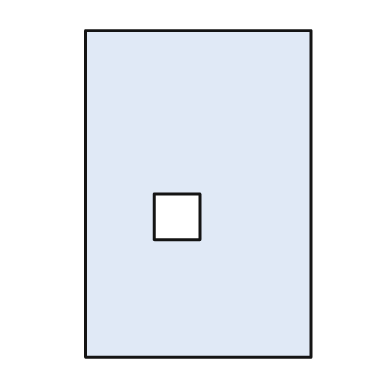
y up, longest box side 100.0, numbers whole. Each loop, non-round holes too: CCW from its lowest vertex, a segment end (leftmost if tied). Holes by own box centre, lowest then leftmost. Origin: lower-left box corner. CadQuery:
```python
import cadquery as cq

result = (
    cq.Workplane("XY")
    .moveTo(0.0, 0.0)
    .lineTo(69.0, 0.0)
    .lineTo(69.0, 100.0)
    .lineTo(0.0, 100.0)
    .close()
    .moveTo(21.0, 36.0)
    .lineTo(35.0, 36.0)
    .lineTo(35.0, 50.0)
    .lineTo(21.0, 50.0)
    .close()
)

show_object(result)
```